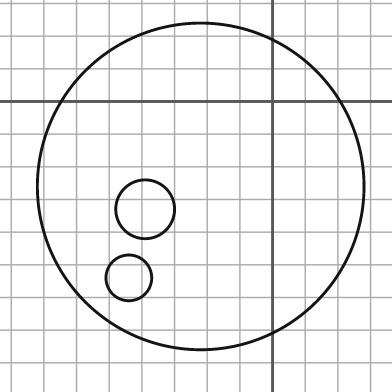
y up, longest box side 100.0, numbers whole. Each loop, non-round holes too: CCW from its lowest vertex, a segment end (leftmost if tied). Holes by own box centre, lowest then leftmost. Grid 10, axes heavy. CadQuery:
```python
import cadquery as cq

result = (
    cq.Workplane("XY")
    .moveTo(-22.0, -26.0)
    .circle(50.0)
    .moveTo(-44.0, -54.0)
    .circle(7.0)
    .moveTo(-39.0, -33.0)
    .circle(9.0)
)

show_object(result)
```